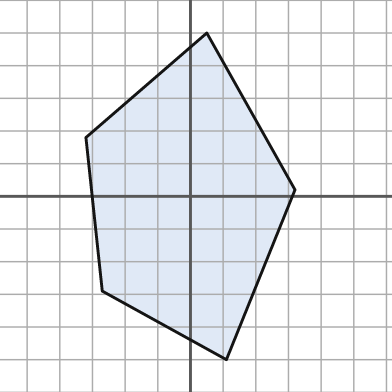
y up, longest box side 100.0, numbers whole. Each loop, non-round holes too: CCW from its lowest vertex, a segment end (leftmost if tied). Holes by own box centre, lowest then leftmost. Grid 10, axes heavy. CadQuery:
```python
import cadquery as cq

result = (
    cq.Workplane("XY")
    .moveTo(11.0, -50.0)
    .lineTo(32.0, 2.0)
    .lineTo(5.0, 50.0)
    .lineTo(-32.0, 18.0)
    .lineTo(-27.0, -29.0)
    .close()
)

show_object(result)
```